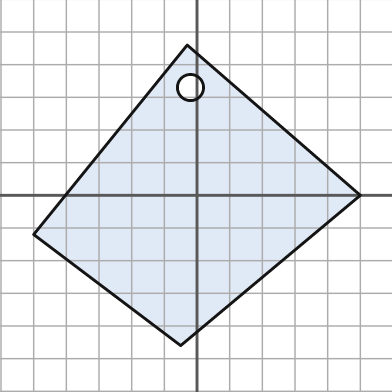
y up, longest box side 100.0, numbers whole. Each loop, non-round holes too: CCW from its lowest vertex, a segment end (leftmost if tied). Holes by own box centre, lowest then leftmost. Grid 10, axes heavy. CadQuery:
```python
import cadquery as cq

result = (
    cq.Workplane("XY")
    .moveTo(-5.0, -46.0)
    .lineTo(50.0, 0.0)
    .lineTo(-3.0, 46.0)
    .lineTo(-50.0, -12.0)
    .close()
    .moveTo(-2.0, 33.0)
    .circle(4.0)
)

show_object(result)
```